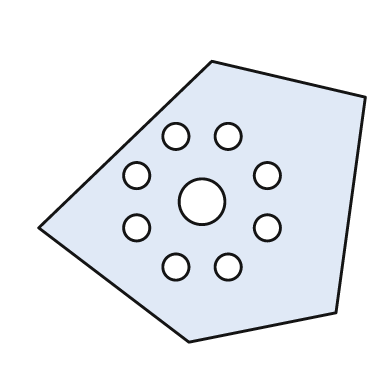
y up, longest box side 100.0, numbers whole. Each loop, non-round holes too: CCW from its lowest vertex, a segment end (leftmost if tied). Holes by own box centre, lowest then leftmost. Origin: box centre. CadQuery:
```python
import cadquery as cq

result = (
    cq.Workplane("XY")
    .moveTo(-4.0, -43.0)
    .lineTo(41.0, -34.0)
    .lineTo(50.0, 32.0)
    .lineTo(3.0, 43.0)
    .lineTo(-50.0, -8.0)
    .close()
    .moveTo(-8.0, -20.0)
    .circle(4.0)
    .moveTo(8.0, -20.0)
    .circle(4.0)
    .moveTo(-20.0, -8.0)
    .circle(4.0)
    .moveTo(20.0, -8.0)
    .circle(4.0)
    .moveTo(0.0, 0.0)
    .circle(7.0)
    .moveTo(-20.0, 8.0)
    .circle(4.0)
    .moveTo(20.0, 8.0)
    .circle(4.0)
    .moveTo(-8.0, 20.0)
    .circle(4.0)
    .moveTo(8.0, 20.0)
    .circle(4.0)
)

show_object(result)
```